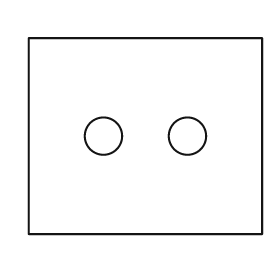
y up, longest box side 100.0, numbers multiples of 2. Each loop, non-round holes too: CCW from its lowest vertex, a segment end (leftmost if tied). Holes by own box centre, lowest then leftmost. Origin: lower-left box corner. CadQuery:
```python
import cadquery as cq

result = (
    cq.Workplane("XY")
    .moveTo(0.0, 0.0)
    .lineTo(100.0, 0.0)
    .lineTo(100.0, 84.0)
    .lineTo(0.0, 84.0)
    .close()
    .moveTo(32.0, 42.0)
    .circle(8.0)
    .moveTo(68.0, 42.0)
    .circle(8.0)
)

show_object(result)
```